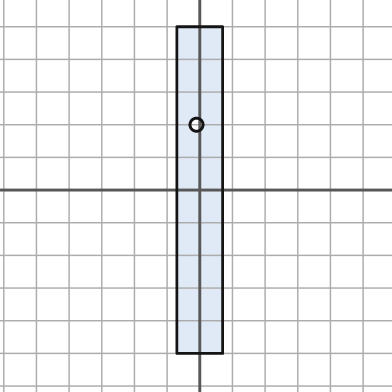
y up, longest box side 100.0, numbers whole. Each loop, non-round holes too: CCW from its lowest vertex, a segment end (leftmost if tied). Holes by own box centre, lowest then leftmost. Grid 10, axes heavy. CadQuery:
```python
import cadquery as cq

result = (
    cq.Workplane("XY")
    .moveTo(-7.0, -50.0)
    .lineTo(7.0, -50.0)
    .lineTo(7.0, 50.0)
    .lineTo(-7.0, 50.0)
    .close()
    .moveTo(-1.0, 20.0)
    .circle(2.0)
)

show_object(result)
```